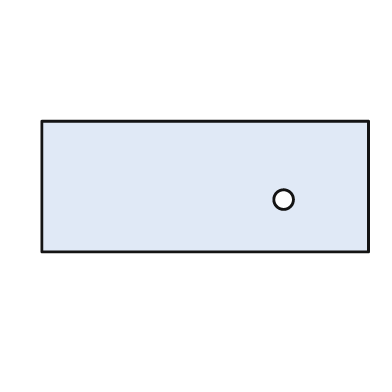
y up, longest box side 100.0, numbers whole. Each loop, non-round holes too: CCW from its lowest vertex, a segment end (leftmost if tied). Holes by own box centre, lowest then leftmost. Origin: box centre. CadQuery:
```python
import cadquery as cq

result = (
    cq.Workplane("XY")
    .moveTo(-50.0, -20.0)
    .lineTo(50.0, -20.0)
    .lineTo(50.0, 20.0)
    .lineTo(-50.0, 20.0)
    .close()
    .moveTo(24.0, -4.0)
    .circle(3.0)
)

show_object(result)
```